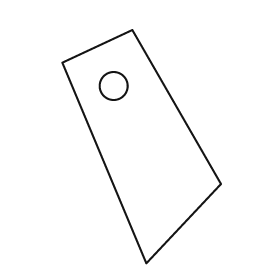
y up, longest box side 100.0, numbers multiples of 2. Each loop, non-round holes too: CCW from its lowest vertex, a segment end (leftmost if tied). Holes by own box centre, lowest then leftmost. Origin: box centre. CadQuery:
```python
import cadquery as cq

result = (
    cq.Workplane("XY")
    .moveTo(2.0, -50.0)
    .lineTo(34.0, -16.0)
    .lineTo(-4.0, 50.0)
    .lineTo(-34.0, 36.0)
    .close()
    .moveTo(-12.0, 26.0)
    .circle(6.0)
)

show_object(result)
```